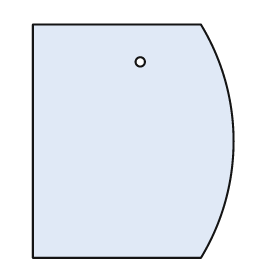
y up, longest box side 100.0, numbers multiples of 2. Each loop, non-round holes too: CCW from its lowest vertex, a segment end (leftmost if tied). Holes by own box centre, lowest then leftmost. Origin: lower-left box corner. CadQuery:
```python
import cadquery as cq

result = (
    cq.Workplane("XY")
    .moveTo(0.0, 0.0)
    .lineTo(72.0, 0.0)
    .threePointArc((86.0, 50.0), (72.0, 100.0))
    .lineTo(0.0, 100.0)
    .close()
    .moveTo(46.0, 84.0)
    .circle(2.0)
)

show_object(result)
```